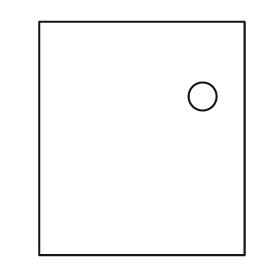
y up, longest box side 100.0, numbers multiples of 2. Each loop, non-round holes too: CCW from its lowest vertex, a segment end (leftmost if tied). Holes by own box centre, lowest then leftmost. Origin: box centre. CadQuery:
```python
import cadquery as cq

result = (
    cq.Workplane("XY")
    .moveTo(-44.0, -50.0)
    .lineTo(44.0, -50.0)
    .lineTo(44.0, 50.0)
    .lineTo(-44.0, 50.0)
    .close()
    .moveTo(26.0, 18.0)
    .circle(6.0)
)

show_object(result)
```